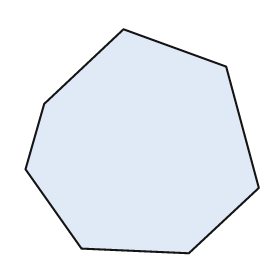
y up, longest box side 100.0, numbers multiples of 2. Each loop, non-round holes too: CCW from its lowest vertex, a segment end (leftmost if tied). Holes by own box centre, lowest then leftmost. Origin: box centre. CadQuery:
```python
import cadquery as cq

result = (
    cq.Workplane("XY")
    .moveTo(20.0, -48.0)
    .lineTo(50.0, -20.0)
    .lineTo(36.0, 32.0)
    .lineTo(-8.0, 48.0)
    .lineTo(-42.0, 16.0)
    .lineTo(-50.0, -12.0)
    .lineTo(-26.0, -46.0)
    .close()
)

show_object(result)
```